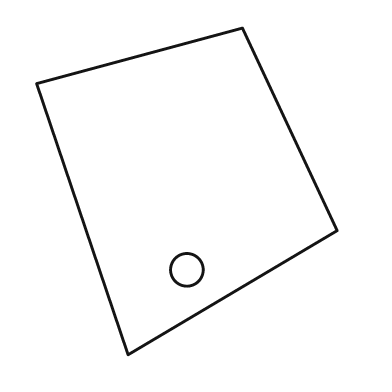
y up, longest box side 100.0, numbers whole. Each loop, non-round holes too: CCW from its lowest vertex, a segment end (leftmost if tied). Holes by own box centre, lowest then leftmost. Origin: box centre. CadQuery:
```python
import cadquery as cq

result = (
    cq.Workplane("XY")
    .moveTo(-18.0, -50.0)
    .lineTo(46.0, -12.0)
    .lineTo(17.0, 50.0)
    .lineTo(-46.0, 33.0)
    .close()
    .moveTo(0.0, -24.0)
    .circle(5.0)
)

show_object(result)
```